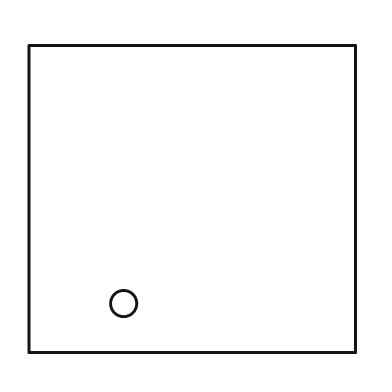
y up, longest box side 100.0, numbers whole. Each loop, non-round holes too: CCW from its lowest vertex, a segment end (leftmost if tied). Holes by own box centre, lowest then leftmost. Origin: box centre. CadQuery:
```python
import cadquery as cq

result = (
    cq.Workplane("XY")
    .moveTo(-50.0, -47.0)
    .lineTo(50.0, -47.0)
    .lineTo(50.0, 47.0)
    .lineTo(-50.0, 47.0)
    .close()
    .moveTo(-21.0, -32.0)
    .circle(4.0)
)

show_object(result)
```